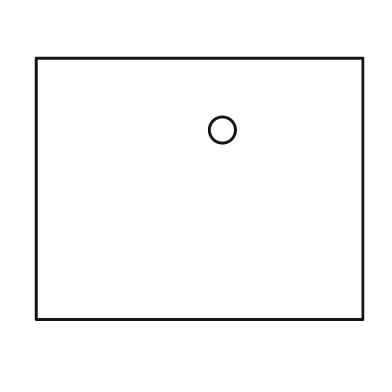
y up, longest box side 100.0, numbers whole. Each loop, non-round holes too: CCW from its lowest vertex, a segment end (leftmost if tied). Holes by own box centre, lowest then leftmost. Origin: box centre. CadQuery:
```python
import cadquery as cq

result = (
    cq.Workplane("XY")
    .moveTo(-50.0, -40.0)
    .lineTo(50.0, -40.0)
    .lineTo(50.0, 40.0)
    .lineTo(-50.0, 40.0)
    .close()
    .moveTo(7.0, 18.0)
    .circle(4.0)
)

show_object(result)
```